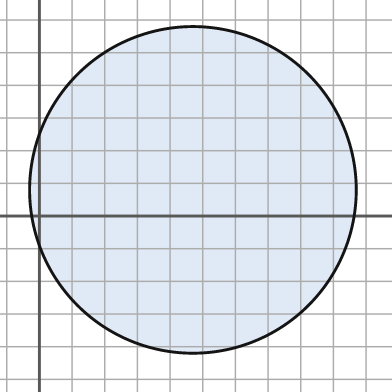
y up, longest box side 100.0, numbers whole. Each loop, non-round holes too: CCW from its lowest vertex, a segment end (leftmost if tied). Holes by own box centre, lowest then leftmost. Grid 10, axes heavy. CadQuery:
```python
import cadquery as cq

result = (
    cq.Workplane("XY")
    .moveTo(47.0, 8.0)
    .circle(50.0)
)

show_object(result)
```